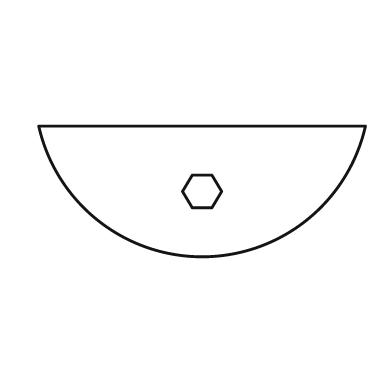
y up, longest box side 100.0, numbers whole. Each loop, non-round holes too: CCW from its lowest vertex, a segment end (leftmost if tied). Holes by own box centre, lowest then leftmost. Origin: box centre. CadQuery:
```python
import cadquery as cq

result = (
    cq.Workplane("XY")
    .moveTo(-50.0, 20.0)
    .threePointArc((0.0, -20.0), (50.0, 20.0))
    .close()
    .moveTo(-3.0, -5.0)
    .lineTo(3.0, -5.0)
    .lineTo(6.0, 0.0)
    .lineTo(3.0, 5.0)
    .lineTo(-3.0, 5.0)
    .lineTo(-6.0, 0.0)
    .close()
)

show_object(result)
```